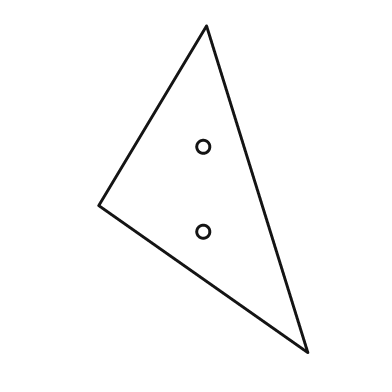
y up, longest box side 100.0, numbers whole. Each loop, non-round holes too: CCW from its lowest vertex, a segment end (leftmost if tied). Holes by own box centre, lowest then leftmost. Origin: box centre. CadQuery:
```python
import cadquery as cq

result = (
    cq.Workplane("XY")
    .moveTo(32.0, -50.0)
    .lineTo(1.0, 50.0)
    .lineTo(-32.0, -5.0)
    .close()
    .moveTo(0.0, -13.0)
    .circle(2.0)
    .moveTo(0.0, 13.0)
    .circle(2.0)
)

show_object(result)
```